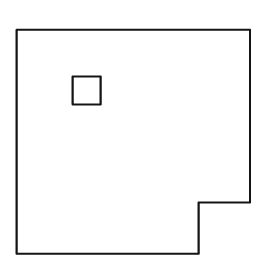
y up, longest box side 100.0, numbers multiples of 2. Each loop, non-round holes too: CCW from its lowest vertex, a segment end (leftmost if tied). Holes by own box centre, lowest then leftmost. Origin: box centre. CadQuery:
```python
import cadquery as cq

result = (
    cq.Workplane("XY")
    .moveTo(-50.0, -48.0)
    .lineTo(28.0, -48.0)
    .lineTo(28.0, -26.0)
    .lineTo(50.0, -26.0)
    .lineTo(50.0, 48.0)
    .lineTo(-50.0, 48.0)
    .close()
    .moveTo(-26.0, 16.0)
    .lineTo(-14.0, 16.0)
    .lineTo(-14.0, 28.0)
    .lineTo(-26.0, 28.0)
    .close()
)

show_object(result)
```